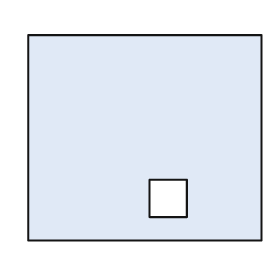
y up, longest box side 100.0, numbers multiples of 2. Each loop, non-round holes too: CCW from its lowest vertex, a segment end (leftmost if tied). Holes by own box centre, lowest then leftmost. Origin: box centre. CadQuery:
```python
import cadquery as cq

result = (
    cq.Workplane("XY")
    .moveTo(-50.0, -44.0)
    .lineTo(50.0, -44.0)
    .lineTo(50.0, 44.0)
    .lineTo(-50.0, 44.0)
    .close()
    .moveTo(2.0, -34.0)
    .lineTo(18.0, -34.0)
    .lineTo(18.0, -18.0)
    .lineTo(2.0, -18.0)
    .close()
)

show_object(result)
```